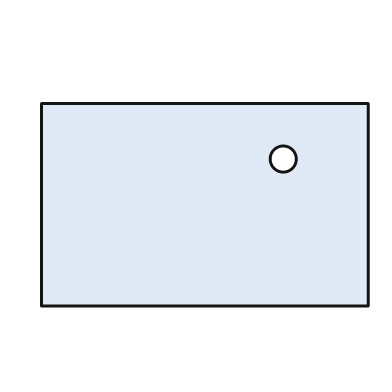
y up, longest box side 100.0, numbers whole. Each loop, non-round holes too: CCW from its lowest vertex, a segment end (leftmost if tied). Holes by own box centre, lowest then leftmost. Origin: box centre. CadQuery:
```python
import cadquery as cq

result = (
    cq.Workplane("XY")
    .moveTo(-50.0, -31.0)
    .lineTo(50.0, -31.0)
    .lineTo(50.0, 31.0)
    .lineTo(-50.0, 31.0)
    .close()
    .moveTo(24.0, 14.0)
    .circle(4.0)
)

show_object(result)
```